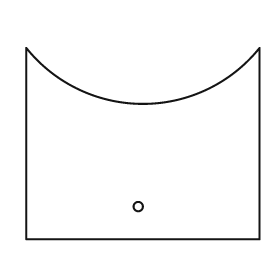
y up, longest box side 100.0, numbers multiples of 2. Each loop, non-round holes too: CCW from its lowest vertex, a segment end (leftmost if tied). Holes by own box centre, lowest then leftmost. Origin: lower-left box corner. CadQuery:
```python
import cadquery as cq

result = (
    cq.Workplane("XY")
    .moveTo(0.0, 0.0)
    .lineTo(100.0, 0.0)
    .lineTo(100.0, 82.0)
    .threePointArc((50.0, 58.0), (0.0, 82.0))
    .close()
    .moveTo(48.0, 14.0)
    .circle(2.0)
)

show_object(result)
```